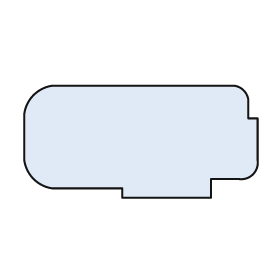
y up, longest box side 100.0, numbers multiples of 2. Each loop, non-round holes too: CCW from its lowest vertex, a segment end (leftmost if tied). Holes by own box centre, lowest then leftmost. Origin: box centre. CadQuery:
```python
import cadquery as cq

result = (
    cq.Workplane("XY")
    .moveTo(-8.0, -24.0)
    .lineTo(30.0, -24.0)
    .lineTo(30.0, -16.0)
    .lineTo(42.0, -16.0)
    .threePointArc((48.0, -14.0), (50.0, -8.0))
    .lineTo(50.0, 10.0)
    .lineTo(46.0, 10.0)
    .lineTo(46.0, 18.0)
    .threePointArc((44.0, 22.0), (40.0, 24.0))
    .lineTo(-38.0, 24.0)
    .threePointArc((-46.0, 20.0), (-50.0, 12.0))
    .lineTo(-50.0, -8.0)
    .threePointArc((-46.0, -16.0), (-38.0, -20.0))
    .lineTo(-8.0, -20.0)
    .close()
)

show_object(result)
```